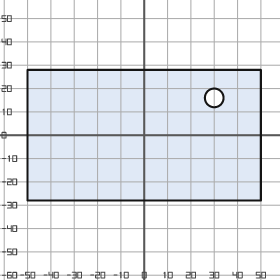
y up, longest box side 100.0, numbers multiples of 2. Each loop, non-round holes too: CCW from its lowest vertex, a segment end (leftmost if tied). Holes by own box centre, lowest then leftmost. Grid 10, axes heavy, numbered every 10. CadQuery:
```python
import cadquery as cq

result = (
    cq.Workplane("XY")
    .moveTo(-50.0, -28.0)
    .lineTo(50.0, -28.0)
    .lineTo(50.0, 28.0)
    .lineTo(-50.0, 28.0)
    .close()
    .moveTo(30.0, 16.0)
    .circle(4.0)
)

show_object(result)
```